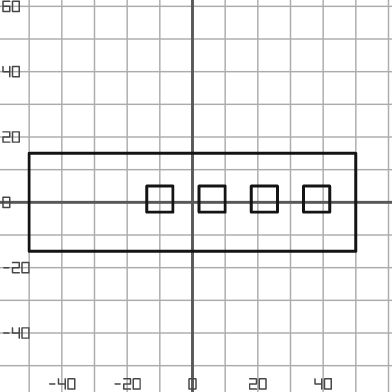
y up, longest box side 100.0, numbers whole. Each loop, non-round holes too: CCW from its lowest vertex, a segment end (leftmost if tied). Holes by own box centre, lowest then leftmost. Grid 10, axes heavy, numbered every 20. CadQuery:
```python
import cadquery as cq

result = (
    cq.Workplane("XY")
    .moveTo(-50.0, -15.0)
    .lineTo(50.0, -15.0)
    .lineTo(50.0, 15.0)
    .lineTo(-50.0, 15.0)
    .close()
    .moveTo(-14.0, -3.0)
    .lineTo(-6.0, -3.0)
    .lineTo(-6.0, 5.0)
    .lineTo(-14.0, 5.0)
    .close()
    .moveTo(2.0, -3.0)
    .lineTo(10.0, -3.0)
    .lineTo(10.0, 5.0)
    .lineTo(2.0, 5.0)
    .close()
    .moveTo(18.0, -3.0)
    .lineTo(26.0, -3.0)
    .lineTo(26.0, 5.0)
    .lineTo(18.0, 5.0)
    .close()
    .moveTo(34.0, -3.0)
    .lineTo(42.0, -3.0)
    .lineTo(42.0, 5.0)
    .lineTo(34.0, 5.0)
    .close()
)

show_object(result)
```